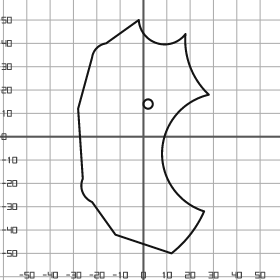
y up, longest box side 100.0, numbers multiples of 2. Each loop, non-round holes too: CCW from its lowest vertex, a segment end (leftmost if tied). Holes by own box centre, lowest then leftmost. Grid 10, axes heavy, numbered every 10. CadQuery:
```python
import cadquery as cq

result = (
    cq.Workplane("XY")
    .moveTo(12.0, -50.0)
    .threePointArc((20.0, -42.0), (26.0, -32.0))
    .threePointArc((8.0, -6.0), (28.0, 18.0))
    .threePointArc((20.0, 30.0), (18.0, 44.0))
    .threePointArc((6.0, 40.0), (-2.0, 50.0))
    .lineTo(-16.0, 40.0)
    .threePointArc((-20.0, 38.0), (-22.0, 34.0))
    .lineTo(-28.0, 12.0)
    .lineTo(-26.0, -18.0)
    .threePointArc((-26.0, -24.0), (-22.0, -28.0))
    .lineTo(-12.0, -42.0)
    .close()
    .moveTo(2.0, 14.0)
    .circle(2.0)
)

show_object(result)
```